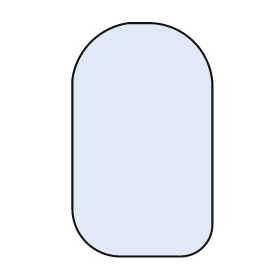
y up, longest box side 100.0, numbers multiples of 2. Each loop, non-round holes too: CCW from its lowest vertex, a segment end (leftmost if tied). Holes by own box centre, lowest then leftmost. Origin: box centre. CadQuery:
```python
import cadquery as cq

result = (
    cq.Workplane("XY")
    .moveTo(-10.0, -50.0)
    .lineTo(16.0, -50.0)
    .threePointArc((26.0, -46.0), (30.0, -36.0))
    .lineTo(30.0, 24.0)
    .threePointArc((22.0, 42.0), (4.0, 50.0))
    .lineTo(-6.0, 50.0)
    .threePointArc((-22.0, 42.0), (-30.0, 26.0))
    .lineTo(-30.0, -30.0)
    .threePointArc((-24.0, -44.0), (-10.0, -50.0))
    .close()
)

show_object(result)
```